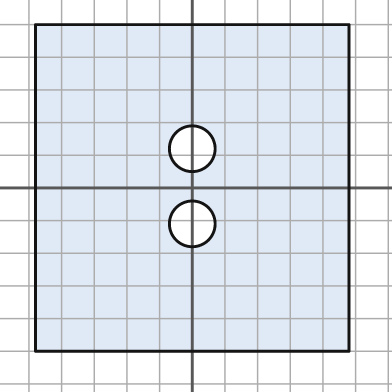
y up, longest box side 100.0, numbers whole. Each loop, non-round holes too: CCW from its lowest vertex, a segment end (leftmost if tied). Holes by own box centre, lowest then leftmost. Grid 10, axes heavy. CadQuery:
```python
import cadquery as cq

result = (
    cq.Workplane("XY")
    .moveTo(-48.0, -50.0)
    .lineTo(48.0, -50.0)
    .lineTo(48.0, 50.0)
    .lineTo(-48.0, 50.0)
    .close()
    .moveTo(0.0, -11.0)
    .circle(7.0)
    .moveTo(0.0, 12.0)
    .circle(7.0)
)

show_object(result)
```